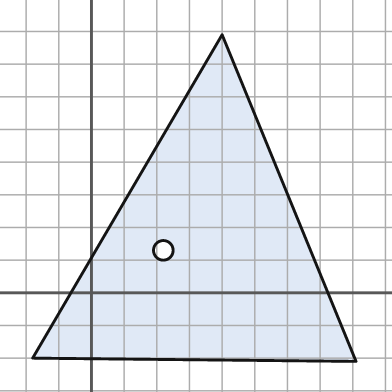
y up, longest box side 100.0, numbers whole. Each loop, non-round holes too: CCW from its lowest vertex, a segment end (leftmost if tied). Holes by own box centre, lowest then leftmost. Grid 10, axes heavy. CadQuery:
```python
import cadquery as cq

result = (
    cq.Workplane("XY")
    .moveTo(81.0, -21.0)
    .lineTo(40.0, 79.0)
    .lineTo(-18.0, -20.0)
    .close()
    .moveTo(22.0, 13.0)
    .circle(3.0)
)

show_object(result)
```